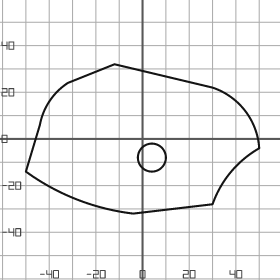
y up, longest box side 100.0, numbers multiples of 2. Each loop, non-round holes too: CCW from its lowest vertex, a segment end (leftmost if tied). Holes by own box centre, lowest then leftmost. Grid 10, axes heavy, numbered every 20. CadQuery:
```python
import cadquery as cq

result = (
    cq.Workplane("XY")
    .moveTo(-4.0, -32.0)
    .lineTo(30.0, -28.0)
    .threePointArc((38.0, -14.0), (50.0, -4.0))
    .threePointArc((44.0, 12.0), (30.0, 22.0))
    .lineTo(-12.0, 32.0)
    .lineTo(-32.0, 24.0)
    .threePointArc((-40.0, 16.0), (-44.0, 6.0))
    .lineTo(-50.0, -14.0)
    .threePointArc((-28.0, -26.0), (-4.0, -32.0))
    .close()
    .moveTo(4.0, -8.0)
    .circle(6.0)
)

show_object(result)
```